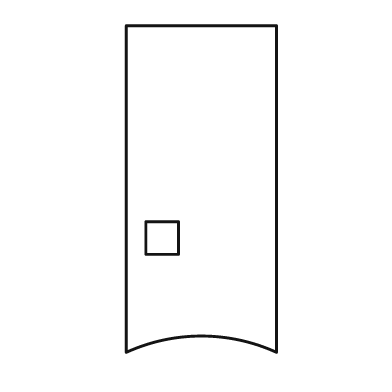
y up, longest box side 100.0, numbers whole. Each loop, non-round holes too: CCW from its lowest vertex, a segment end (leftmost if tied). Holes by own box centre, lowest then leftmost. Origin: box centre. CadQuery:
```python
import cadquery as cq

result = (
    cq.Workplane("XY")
    .moveTo(-23.0, -50.0)
    .threePointArc((0.0, -45.0), (23.0, -50.0))
    .lineTo(23.0, 50.0)
    .lineTo(-23.0, 50.0)
    .close()
    .moveTo(-17.0, -20.0)
    .lineTo(-7.0, -20.0)
    .lineTo(-7.0, -10.0)
    .lineTo(-17.0, -10.0)
    .close()
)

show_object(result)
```